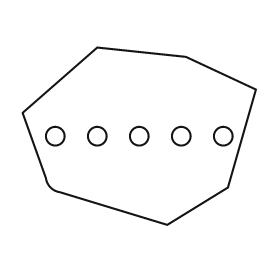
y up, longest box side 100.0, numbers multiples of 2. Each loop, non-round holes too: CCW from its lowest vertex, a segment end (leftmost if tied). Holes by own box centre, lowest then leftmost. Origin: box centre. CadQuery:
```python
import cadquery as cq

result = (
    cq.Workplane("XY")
    .moveTo(12.0, -38.0)
    .lineTo(38.0, -22.0)
    .lineTo(50.0, 20.0)
    .lineTo(20.0, 34.0)
    .lineTo(-18.0, 38.0)
    .lineTo(-50.0, 10.0)
    .lineTo(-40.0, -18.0)
    .threePointArc((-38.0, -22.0), (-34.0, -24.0))
    .close()
    .moveTo(-36.0, 0.0)
    .circle(4.0)
    .moveTo(-18.0, 0.0)
    .circle(4.0)
    .moveTo(0.0, 0.0)
    .circle(4.0)
    .moveTo(18.0, 0.0)
    .circle(4.0)
    .moveTo(36.0, 0.0)
    .circle(4.0)
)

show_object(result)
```